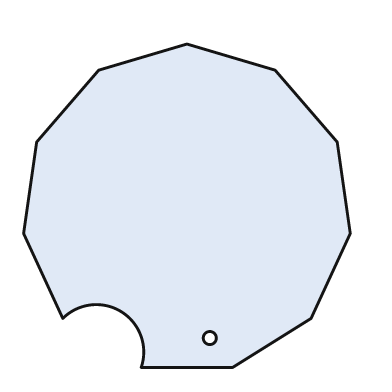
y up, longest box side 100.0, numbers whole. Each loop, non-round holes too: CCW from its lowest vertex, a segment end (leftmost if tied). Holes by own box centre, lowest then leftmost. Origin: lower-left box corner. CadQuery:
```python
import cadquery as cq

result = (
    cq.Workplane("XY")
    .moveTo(36.0, 0.0)
    .lineTo(64.0, 0.0)
    .lineTo(88.0, 15.0)
    .lineTo(100.0, 41.0)
    .lineTo(96.0, 69.0)
    .lineTo(77.0, 91.0)
    .lineTo(50.0, 99.0)
    .lineTo(23.0, 91.0)
    .lineTo(4.0, 69.0)
    .lineTo(0.0, 41.0)
    .lineTo(12.0, 15.0)
    .threePointArc((30.0, 17.0), (36.0, 0.0))
    .close()
    .moveTo(57.0, 9.0)
    .circle(2.0)
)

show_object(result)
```